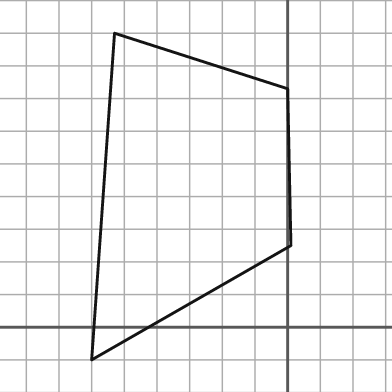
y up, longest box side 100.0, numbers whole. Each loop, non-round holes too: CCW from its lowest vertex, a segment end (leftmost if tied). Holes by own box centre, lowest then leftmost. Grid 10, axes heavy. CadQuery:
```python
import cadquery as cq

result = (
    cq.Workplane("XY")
    .moveTo(-60.0, -10.0)
    .lineTo(1.0, 25.0)
    .lineTo(0.0, 73.0)
    .lineTo(-53.0, 90.0)
    .close()
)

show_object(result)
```